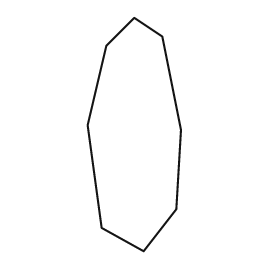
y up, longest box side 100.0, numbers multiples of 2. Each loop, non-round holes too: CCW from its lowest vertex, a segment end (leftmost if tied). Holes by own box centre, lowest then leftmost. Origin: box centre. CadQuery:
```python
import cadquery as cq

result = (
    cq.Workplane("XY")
    .moveTo(4.0, -50.0)
    .lineTo(18.0, -32.0)
    .lineTo(20.0, 2.0)
    .lineTo(12.0, 42.0)
    .lineTo(0.0, 50.0)
    .lineTo(-12.0, 38.0)
    .lineTo(-20.0, 4.0)
    .lineTo(-14.0, -40.0)
    .close()
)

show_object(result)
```